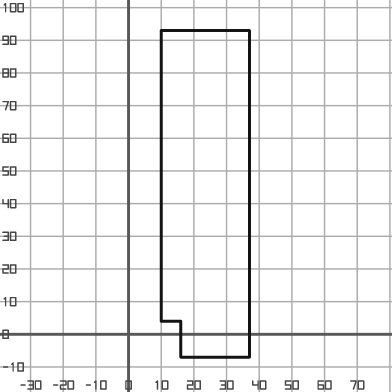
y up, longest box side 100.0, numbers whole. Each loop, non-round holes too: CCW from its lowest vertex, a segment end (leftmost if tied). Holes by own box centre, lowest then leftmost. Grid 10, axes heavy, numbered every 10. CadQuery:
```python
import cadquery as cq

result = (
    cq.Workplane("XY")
    .moveTo(16.0, -7.0)
    .lineTo(37.0, -7.0)
    .lineTo(37.0, 93.0)
    .lineTo(10.0, 93.0)
    .lineTo(10.0, 4.0)
    .lineTo(16.0, 4.0)
    .close()
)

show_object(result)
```